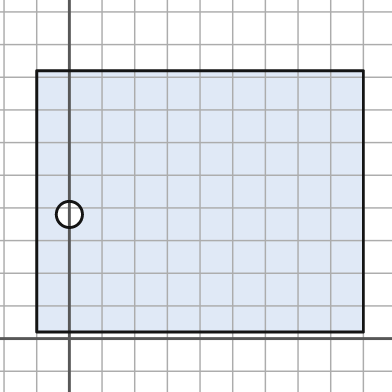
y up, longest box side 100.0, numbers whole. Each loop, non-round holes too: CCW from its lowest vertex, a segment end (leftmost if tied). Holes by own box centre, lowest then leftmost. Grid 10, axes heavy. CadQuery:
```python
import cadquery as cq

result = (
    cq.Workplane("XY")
    .moveTo(-10.0, 2.0)
    .lineTo(90.0, 2.0)
    .lineTo(90.0, 82.0)
    .lineTo(-10.0, 82.0)
    .close()
    .moveTo(0.0, 38.0)
    .circle(4.0)
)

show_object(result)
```